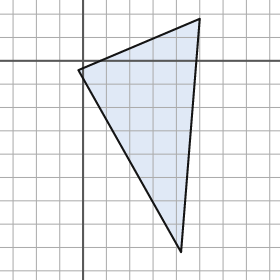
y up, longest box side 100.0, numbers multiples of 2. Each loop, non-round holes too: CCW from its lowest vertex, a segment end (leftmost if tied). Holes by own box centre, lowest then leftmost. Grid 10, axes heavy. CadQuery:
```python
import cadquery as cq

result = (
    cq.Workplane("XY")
    .moveTo(42.0, -82.0)
    .lineTo(50.0, 18.0)
    .lineTo(-2.0, -4.0)
    .close()
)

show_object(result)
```